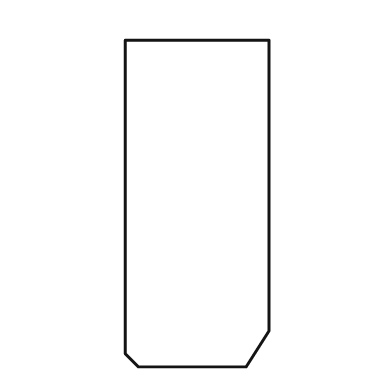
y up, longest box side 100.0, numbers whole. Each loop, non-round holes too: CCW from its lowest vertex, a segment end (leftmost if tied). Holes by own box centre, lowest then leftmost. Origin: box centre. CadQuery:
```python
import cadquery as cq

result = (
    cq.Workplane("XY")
    .moveTo(-18.0, -50.0)
    .lineTo(15.0, -50.0)
    .lineTo(22.0, -39.0)
    .lineTo(22.0, 50.0)
    .lineTo(-22.0, 50.0)
    .lineTo(-22.0, -46.0)
    .close()
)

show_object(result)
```